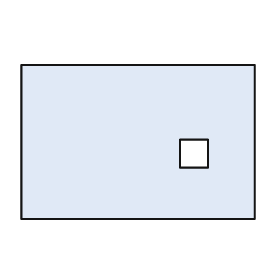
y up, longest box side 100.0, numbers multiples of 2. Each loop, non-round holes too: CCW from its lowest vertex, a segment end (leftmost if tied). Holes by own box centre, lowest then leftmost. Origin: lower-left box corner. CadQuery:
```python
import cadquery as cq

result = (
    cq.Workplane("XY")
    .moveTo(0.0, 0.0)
    .lineTo(100.0, 0.0)
    .lineTo(100.0, 66.0)
    .lineTo(0.0, 66.0)
    .close()
    .moveTo(68.0, 22.0)
    .lineTo(80.0, 22.0)
    .lineTo(80.0, 34.0)
    .lineTo(68.0, 34.0)
    .close()
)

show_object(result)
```